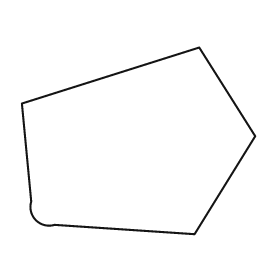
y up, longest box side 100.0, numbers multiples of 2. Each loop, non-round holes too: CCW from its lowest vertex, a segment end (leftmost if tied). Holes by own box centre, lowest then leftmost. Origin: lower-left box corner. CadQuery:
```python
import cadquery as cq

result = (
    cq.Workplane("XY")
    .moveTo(74.0, 0.0)
    .lineTo(100.0, 42.0)
    .lineTo(76.0, 80.0)
    .lineTo(0.0, 56.0)
    .lineTo(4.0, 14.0)
    .threePointArc((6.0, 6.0), (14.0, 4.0))
    .close()
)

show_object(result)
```